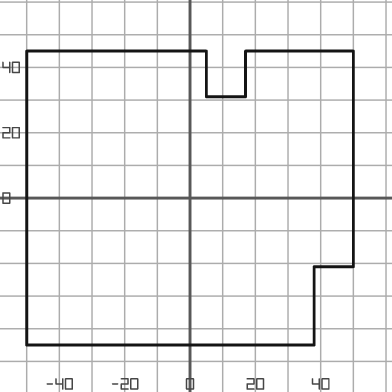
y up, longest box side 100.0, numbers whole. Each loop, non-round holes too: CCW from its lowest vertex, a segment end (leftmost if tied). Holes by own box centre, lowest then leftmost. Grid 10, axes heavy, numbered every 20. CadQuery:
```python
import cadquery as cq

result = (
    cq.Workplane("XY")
    .moveTo(-50.0, -45.0)
    .lineTo(38.0, -45.0)
    .lineTo(38.0, -21.0)
    .lineTo(50.0, -21.0)
    .lineTo(50.0, 45.0)
    .lineTo(17.0, 45.0)
    .lineTo(17.0, 31.0)
    .lineTo(5.0, 31.0)
    .lineTo(5.0, 45.0)
    .lineTo(-50.0, 45.0)
    .close()
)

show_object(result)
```